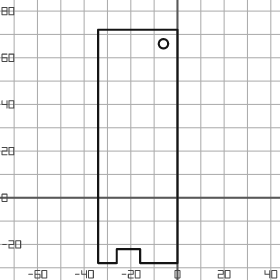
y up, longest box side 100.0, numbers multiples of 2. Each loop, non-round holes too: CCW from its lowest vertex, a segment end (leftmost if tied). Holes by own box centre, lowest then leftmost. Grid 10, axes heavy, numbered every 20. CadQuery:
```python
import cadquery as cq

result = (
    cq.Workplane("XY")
    .moveTo(-34.0, -28.0)
    .lineTo(-26.0, -28.0)
    .lineTo(-26.0, -22.0)
    .lineTo(-16.0, -22.0)
    .lineTo(-16.0, -28.0)
    .lineTo(0.0, -28.0)
    .lineTo(0.0, 72.0)
    .lineTo(-34.0, 72.0)
    .close()
    .moveTo(-6.0, 66.0)
    .circle(2.0)
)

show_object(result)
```